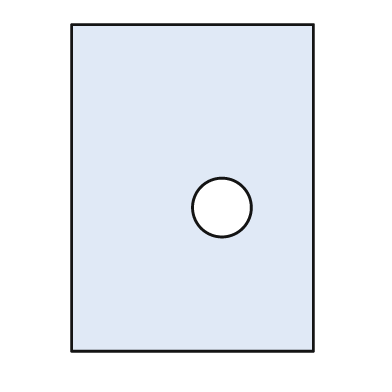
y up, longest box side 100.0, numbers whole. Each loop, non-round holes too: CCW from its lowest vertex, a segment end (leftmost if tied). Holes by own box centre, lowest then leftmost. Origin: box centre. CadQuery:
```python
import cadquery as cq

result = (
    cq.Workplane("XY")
    .moveTo(-37.0, -50.0)
    .lineTo(37.0, -50.0)
    .lineTo(37.0, 50.0)
    .lineTo(-37.0, 50.0)
    .close()
    .moveTo(9.0, -6.0)
    .circle(9.0)
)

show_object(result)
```